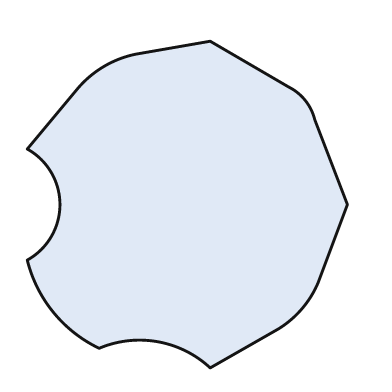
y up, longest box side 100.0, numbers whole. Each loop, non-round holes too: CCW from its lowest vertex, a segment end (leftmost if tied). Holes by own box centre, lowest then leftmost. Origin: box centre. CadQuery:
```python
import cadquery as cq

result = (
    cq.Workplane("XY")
    .moveTo(7.0, -50.0)
    .lineTo(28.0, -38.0)
    .threePointArc((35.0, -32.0), (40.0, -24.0))
    .lineTo(49.0, 0.0)
    .lineTo(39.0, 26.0)
    .threePointArc((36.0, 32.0), (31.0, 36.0))
    .lineTo(7.0, 50.0)
    .lineTo(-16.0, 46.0)
    .threePointArc((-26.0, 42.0), (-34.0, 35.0))
    .lineTo(-49.0, 17.0)
    .threePointArc((-39.0, 0.0), (-49.0, -17.0))
    .threePointArc((-41.0, -33.0), (-27.0, -44.0))
    .threePointArc((-9.0, -42.0), (7.0, -50.0))
    .close()
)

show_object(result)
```